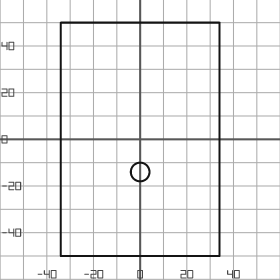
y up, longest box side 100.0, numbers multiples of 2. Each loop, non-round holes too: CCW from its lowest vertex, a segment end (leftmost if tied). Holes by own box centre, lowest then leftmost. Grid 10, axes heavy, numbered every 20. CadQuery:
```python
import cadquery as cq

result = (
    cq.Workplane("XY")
    .moveTo(-34.0, -50.0)
    .lineTo(34.0, -50.0)
    .lineTo(34.0, 50.0)
    .lineTo(-34.0, 50.0)
    .close()
    .moveTo(0.0, -14.0)
    .circle(4.0)
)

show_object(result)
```